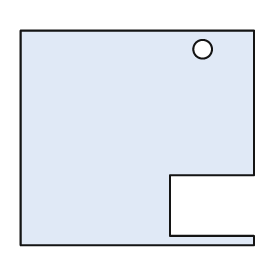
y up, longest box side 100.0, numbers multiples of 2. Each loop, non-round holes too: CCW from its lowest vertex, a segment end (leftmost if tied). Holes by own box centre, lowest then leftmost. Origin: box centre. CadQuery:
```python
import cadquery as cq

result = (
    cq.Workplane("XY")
    .moveTo(-50.0, -46.0)
    .lineTo(50.0, -46.0)
    .lineTo(50.0, -42.0)
    .lineTo(14.0, -42.0)
    .lineTo(14.0, -16.0)
    .lineTo(50.0, -16.0)
    .lineTo(50.0, 46.0)
    .lineTo(-50.0, 46.0)
    .close()
    .moveTo(28.0, 38.0)
    .circle(4.0)
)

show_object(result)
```